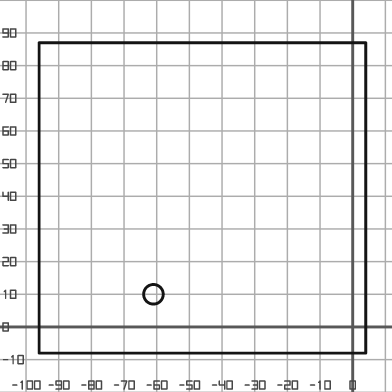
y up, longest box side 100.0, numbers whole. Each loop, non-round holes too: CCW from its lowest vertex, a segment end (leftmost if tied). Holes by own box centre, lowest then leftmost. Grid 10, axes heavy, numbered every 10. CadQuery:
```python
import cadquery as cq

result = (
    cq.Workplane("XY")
    .moveTo(-96.0, -8.0)
    .lineTo(4.0, -8.0)
    .lineTo(4.0, 87.0)
    .lineTo(-96.0, 87.0)
    .close()
    .moveTo(-61.0, 10.0)
    .circle(3.0)
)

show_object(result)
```